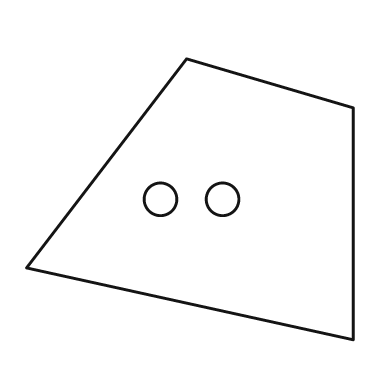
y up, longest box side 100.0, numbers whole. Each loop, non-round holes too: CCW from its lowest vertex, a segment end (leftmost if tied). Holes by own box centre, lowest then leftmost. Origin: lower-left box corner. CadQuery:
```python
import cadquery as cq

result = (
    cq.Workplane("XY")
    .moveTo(100.0, 0.0)
    .lineTo(100.0, 71.0)
    .lineTo(49.0, 86.0)
    .lineTo(0.0, 22.0)
    .close()
    .moveTo(41.0, 43.0)
    .circle(5.0)
    .moveTo(60.0, 43.0)
    .circle(5.0)
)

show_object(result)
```